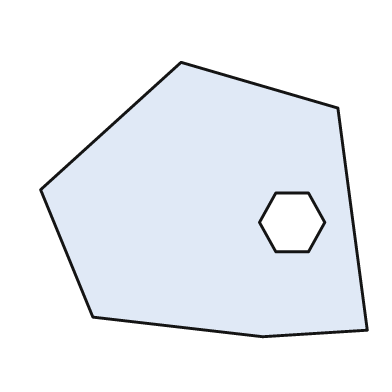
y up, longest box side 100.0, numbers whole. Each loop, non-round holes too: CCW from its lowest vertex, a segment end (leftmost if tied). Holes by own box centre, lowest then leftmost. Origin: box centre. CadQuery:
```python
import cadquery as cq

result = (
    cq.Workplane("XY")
    .moveTo(18.0, -42.0)
    .lineTo(50.0, -40.0)
    .lineTo(41.0, 28.0)
    .lineTo(-7.0, 42.0)
    .lineTo(-50.0, 3.0)
    .lineTo(-34.0, -36.0)
    .close()
    .moveTo(22.0, -16.0)
    .lineTo(32.0, -16.0)
    .lineTo(37.0, -7.0)
    .lineTo(32.0, 2.0)
    .lineTo(22.0, 2.0)
    .lineTo(17.0, -7.0)
    .close()
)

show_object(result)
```